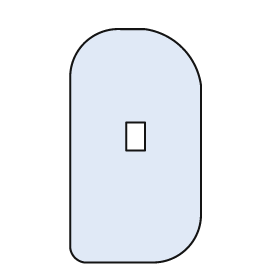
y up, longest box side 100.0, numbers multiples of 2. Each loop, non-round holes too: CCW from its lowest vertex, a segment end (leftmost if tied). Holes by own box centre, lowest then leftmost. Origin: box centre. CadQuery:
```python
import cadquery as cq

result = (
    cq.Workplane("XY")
    .moveTo(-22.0, -50.0)
    .lineTo(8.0, -50.0)
    .threePointArc((22.0, -44.0), (28.0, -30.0))
    .lineTo(28.0, 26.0)
    .threePointArc((20.0, 42.0), (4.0, 50.0))
    .lineTo(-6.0, 50.0)
    .threePointArc((-22.0, 44.0), (-28.0, 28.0))
    .lineTo(-28.0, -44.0)
    .threePointArc((-26.0, -48.0), (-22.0, -50.0))
    .close()
    .moveTo(-4.0, -2.0)
    .lineTo(4.0, -2.0)
    .lineTo(4.0, 10.0)
    .lineTo(-4.0, 10.0)
    .close()
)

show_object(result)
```